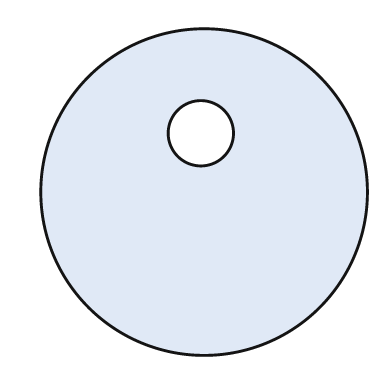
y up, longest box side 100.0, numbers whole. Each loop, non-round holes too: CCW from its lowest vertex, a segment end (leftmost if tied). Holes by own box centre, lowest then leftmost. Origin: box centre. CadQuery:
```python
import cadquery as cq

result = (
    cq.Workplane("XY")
    .moveTo(0.0, 0.0)
    .circle(50.0)
    .moveTo(-1.0, 18.0)
    .circle(10.0)
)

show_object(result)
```